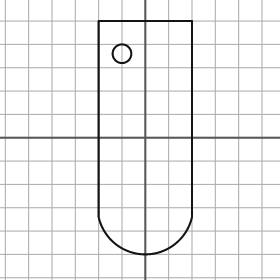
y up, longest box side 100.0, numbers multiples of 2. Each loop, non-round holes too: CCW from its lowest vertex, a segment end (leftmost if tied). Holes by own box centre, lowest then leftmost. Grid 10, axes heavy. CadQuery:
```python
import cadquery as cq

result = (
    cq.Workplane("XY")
    .moveTo(-20.0, -34.0)
    .threePointArc((0.0, -50.0), (20.0, -34.0))
    .lineTo(20.0, 50.0)
    .lineTo(-20.0, 50.0)
    .close()
    .moveTo(-10.0, 36.0)
    .circle(4.0)
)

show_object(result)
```